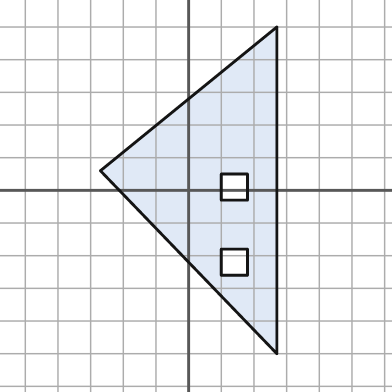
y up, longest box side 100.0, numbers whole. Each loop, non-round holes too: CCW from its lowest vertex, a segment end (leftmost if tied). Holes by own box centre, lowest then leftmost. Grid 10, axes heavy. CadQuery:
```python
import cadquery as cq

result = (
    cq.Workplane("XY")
    .moveTo(27.0, -50.0)
    .lineTo(27.0, 50.0)
    .lineTo(-27.0, 6.0)
    .close()
    .moveTo(10.0, -26.0)
    .lineTo(18.0, -26.0)
    .lineTo(18.0, -18.0)
    .lineTo(10.0, -18.0)
    .close()
    .moveTo(10.0, -3.0)
    .lineTo(18.0, -3.0)
    .lineTo(18.0, 5.0)
    .lineTo(10.0, 5.0)
    .close()
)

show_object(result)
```